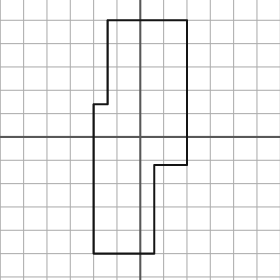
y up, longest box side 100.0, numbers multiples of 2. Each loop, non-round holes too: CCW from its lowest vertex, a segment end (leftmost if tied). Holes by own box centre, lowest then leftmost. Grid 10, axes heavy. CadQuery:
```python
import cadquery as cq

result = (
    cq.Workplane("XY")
    .moveTo(-20.0, -50.0)
    .lineTo(6.0, -50.0)
    .lineTo(6.0, -12.0)
    .lineTo(20.0, -12.0)
    .lineTo(20.0, 50.0)
    .lineTo(-14.0, 50.0)
    .lineTo(-14.0, 14.0)
    .lineTo(-20.0, 14.0)
    .close()
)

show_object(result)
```